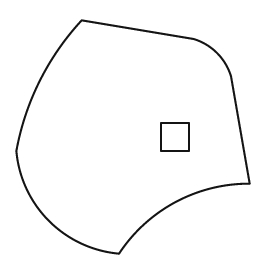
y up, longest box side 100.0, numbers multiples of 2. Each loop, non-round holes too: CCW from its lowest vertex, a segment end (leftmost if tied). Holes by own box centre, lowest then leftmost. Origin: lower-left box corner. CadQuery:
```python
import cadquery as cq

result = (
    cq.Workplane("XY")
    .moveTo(44.0, 0.0)
    .threePointArc((68.0, 22.0), (100.0, 30.0))
    .lineTo(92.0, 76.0)
    .threePointArc((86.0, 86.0), (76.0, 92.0))
    .lineTo(28.0, 100.0)
    .threePointArc((10.0, 74.0), (0.0, 44.0))
    .threePointArc((14.0, 14.0), (44.0, 0.0))
    .close()
    .moveTo(62.0, 44.0)
    .lineTo(74.0, 44.0)
    .lineTo(74.0, 56.0)
    .lineTo(62.0, 56.0)
    .close()
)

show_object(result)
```